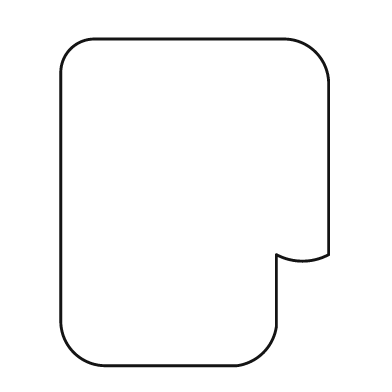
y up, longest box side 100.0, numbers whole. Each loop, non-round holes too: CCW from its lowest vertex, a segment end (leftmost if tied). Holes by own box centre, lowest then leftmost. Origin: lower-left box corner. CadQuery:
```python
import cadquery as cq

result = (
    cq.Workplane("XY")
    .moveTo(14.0, 0.0)
    .lineTo(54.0, 0.0)
    .threePointArc((62.0, 4.0), (66.0, 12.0))
    .lineTo(66.0, 34.0)
    .threePointArc((74.0, 32.0), (82.0, 34.0))
    .lineTo(82.0, 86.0)
    .threePointArc((78.0, 96.0), (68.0, 100.0))
    .lineTo(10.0, 100.0)
    .threePointArc((3.0, 97.0), (0.0, 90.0))
    .lineTo(0.0, 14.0)
    .threePointArc((4.0, 4.0), (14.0, 0.0))
    .close()
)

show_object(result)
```